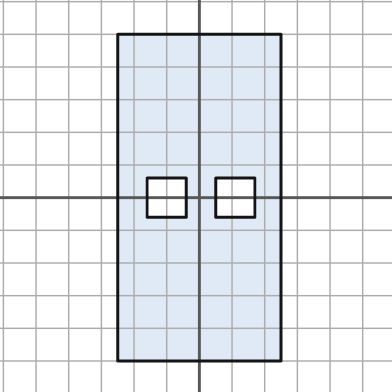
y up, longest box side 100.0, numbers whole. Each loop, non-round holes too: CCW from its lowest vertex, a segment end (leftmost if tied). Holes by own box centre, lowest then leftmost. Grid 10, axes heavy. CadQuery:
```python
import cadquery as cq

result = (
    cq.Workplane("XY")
    .moveTo(-25.0, -50.0)
    .lineTo(25.0, -50.0)
    .lineTo(25.0, 50.0)
    .lineTo(-25.0, 50.0)
    .close()
    .moveTo(-16.0, -6.0)
    .lineTo(-4.0, -6.0)
    .lineTo(-4.0, 6.0)
    .lineTo(-16.0, 6.0)
    .close()
    .moveTo(5.0, -6.0)
    .lineTo(17.0, -6.0)
    .lineTo(17.0, 6.0)
    .lineTo(5.0, 6.0)
    .close()
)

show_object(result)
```